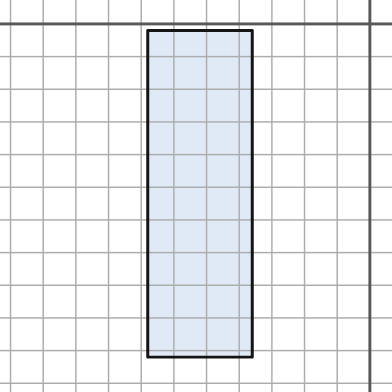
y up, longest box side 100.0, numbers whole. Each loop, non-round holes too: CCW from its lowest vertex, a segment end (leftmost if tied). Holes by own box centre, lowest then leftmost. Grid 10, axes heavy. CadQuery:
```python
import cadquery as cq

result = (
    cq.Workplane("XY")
    .moveTo(-68.0, -102.0)
    .lineTo(-36.0, -102.0)
    .lineTo(-36.0, -2.0)
    .lineTo(-68.0, -2.0)
    .close()
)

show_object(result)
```